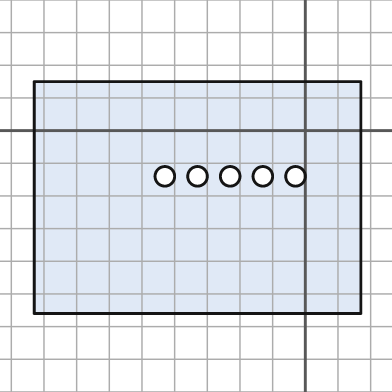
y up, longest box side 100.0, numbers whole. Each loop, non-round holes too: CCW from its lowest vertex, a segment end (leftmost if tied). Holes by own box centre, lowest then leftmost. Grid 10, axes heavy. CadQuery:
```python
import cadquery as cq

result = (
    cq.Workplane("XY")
    .moveTo(-83.0, -56.0)
    .lineTo(17.0, -56.0)
    .lineTo(17.0, 15.0)
    .lineTo(-83.0, 15.0)
    .close()
    .moveTo(-43.0, -14.0)
    .circle(3.0)
    .moveTo(-33.0, -14.0)
    .circle(3.0)
    .moveTo(-23.0, -14.0)
    .circle(3.0)
    .moveTo(-13.0, -14.0)
    .circle(3.0)
    .moveTo(-3.0, -14.0)
    .circle(3.0)
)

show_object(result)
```